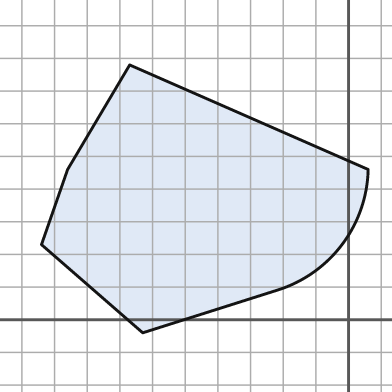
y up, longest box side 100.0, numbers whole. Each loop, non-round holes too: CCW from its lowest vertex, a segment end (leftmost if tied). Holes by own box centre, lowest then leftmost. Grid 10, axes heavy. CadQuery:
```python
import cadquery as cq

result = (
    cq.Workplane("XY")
    .moveTo(-63.0, -4.0)
    .lineTo(-22.0, 9.0)
    .threePointArc((-2.0, 23.0), (6.0, 46.0))
    .lineTo(-67.0, 78.0)
    .lineTo(-86.0, 46.0)
    .lineTo(-94.0, 23.0)
    .close()
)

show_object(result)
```